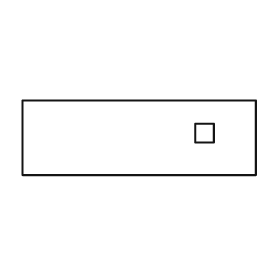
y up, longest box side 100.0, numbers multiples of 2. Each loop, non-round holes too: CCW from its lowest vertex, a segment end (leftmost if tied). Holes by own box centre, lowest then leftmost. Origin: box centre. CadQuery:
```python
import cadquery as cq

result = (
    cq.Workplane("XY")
    .moveTo(-50.0, -16.0)
    .lineTo(50.0, -16.0)
    .lineTo(50.0, 16.0)
    .lineTo(-50.0, 16.0)
    .close()
    .moveTo(24.0, -2.0)
    .lineTo(32.0, -2.0)
    .lineTo(32.0, 6.0)
    .lineTo(24.0, 6.0)
    .close()
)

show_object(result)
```